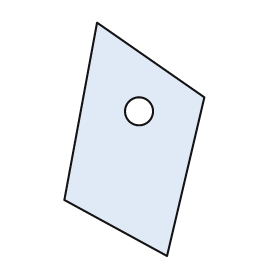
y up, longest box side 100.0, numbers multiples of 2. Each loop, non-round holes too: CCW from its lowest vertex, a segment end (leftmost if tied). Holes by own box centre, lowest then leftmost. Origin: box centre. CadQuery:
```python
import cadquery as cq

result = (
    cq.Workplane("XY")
    .moveTo(14.0, -50.0)
    .lineTo(30.0, 18.0)
    .lineTo(-16.0, 50.0)
    .lineTo(-30.0, -26.0)
    .close()
    .moveTo(2.0, 12.0)
    .circle(6.0)
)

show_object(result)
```